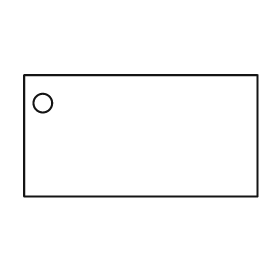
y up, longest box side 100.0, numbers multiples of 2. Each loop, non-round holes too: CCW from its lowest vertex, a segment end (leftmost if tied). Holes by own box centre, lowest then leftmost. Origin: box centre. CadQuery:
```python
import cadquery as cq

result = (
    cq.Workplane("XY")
    .moveTo(-50.0, -26.0)
    .lineTo(50.0, -26.0)
    .lineTo(50.0, 26.0)
    .lineTo(-50.0, 26.0)
    .close()
    .moveTo(-42.0, 14.0)
    .circle(4.0)
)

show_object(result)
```